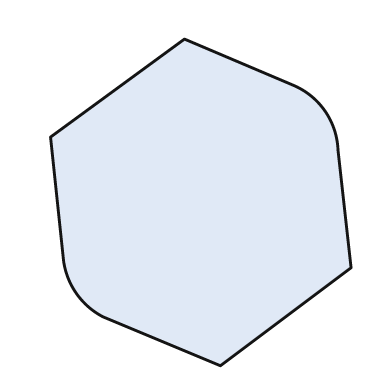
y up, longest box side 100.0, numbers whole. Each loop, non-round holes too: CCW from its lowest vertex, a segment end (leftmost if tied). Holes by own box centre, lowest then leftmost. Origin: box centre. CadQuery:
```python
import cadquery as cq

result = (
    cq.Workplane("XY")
    .moveTo(6.0, -50.0)
    .lineTo(46.0, -20.0)
    .lineTo(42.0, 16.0)
    .threePointArc((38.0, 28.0), (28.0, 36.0))
    .lineTo(-5.0, 50.0)
    .lineTo(-46.0, 20.0)
    .lineTo(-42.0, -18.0)
    .threePointArc((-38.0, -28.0), (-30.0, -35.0))
    .close()
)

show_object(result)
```